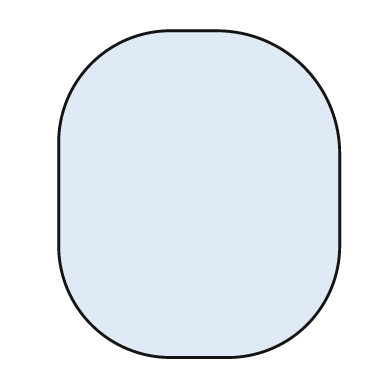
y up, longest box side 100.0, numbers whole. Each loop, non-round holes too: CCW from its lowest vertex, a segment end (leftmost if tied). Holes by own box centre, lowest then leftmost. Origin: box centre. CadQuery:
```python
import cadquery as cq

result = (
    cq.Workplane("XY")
    .moveTo(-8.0, -50.0)
    .lineTo(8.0, -50.0)
    .threePointArc((33.0, -40.0), (43.0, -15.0))
    .lineTo(43.0, 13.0)
    .threePointArc((32.0, 39.0), (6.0, 50.0))
    .lineTo(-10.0, 50.0)
    .threePointArc((-33.0, 40.0), (-43.0, 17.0))
    .lineTo(-43.0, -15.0)
    .threePointArc((-33.0, -40.0), (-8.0, -50.0))
    .close()
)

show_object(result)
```